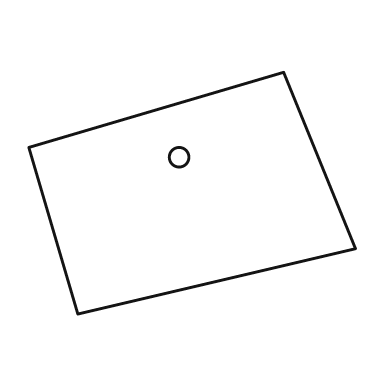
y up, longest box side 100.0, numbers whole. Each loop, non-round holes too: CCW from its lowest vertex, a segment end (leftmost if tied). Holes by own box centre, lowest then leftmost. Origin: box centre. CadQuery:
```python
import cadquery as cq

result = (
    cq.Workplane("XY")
    .moveTo(-35.0, -37.0)
    .lineTo(50.0, -17.0)
    .lineTo(28.0, 37.0)
    .lineTo(-50.0, 14.0)
    .close()
    .moveTo(-4.0, 11.0)
    .circle(3.0)
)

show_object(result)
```